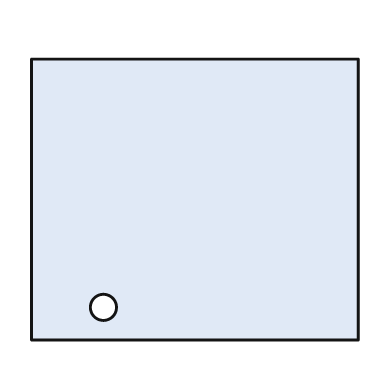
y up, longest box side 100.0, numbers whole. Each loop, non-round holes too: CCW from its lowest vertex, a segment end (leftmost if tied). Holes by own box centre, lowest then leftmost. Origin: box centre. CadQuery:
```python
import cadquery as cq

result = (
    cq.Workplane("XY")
    .moveTo(-50.0, -43.0)
    .lineTo(50.0, -43.0)
    .lineTo(50.0, 43.0)
    .lineTo(-50.0, 43.0)
    .close()
    .moveTo(-28.0, -33.0)
    .circle(4.0)
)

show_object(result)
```